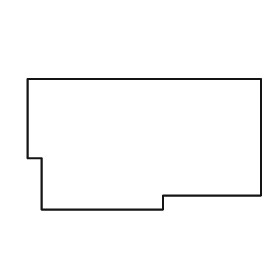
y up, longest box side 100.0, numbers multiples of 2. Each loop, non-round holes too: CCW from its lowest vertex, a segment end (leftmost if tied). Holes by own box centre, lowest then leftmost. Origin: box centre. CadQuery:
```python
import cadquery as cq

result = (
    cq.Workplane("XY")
    .moveTo(-44.0, -28.0)
    .lineTo(8.0, -28.0)
    .lineTo(8.0, -22.0)
    .lineTo(50.0, -22.0)
    .lineTo(50.0, 28.0)
    .lineTo(-50.0, 28.0)
    .lineTo(-50.0, -6.0)
    .lineTo(-44.0, -6.0)
    .close()
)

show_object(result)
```